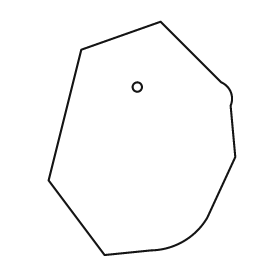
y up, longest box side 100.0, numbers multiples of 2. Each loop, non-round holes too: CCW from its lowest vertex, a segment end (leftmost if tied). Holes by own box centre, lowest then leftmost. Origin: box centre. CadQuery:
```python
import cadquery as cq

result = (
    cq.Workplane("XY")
    .moveTo(-16.0, -50.0)
    .lineTo(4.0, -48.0)
    .threePointArc((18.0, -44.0), (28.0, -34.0))
    .lineTo(40.0, -8.0)
    .lineTo(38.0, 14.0)
    .threePointArc((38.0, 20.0), (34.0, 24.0))
    .lineTo(8.0, 50.0)
    .lineTo(-26.0, 38.0)
    .lineTo(-40.0, -18.0)
    .close()
    .moveTo(-2.0, 22.0)
    .circle(2.0)
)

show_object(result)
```